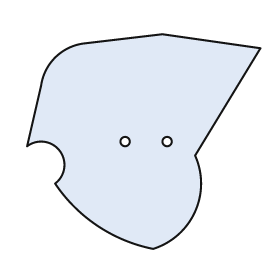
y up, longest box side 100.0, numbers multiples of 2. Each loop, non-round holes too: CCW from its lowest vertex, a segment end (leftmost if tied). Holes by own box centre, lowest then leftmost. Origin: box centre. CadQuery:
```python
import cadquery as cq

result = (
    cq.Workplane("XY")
    .moveTo(4.0, -46.0)
    .threePointArc((22.0, -30.0), (22.0, -6.0))
    .lineTo(50.0, 40.0)
    .lineTo(8.0, 46.0)
    .lineTo(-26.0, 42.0)
    .threePointArc((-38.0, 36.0), (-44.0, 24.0))
    .lineTo(-50.0, -2.0)
    .threePointArc((-36.0, -4.0), (-38.0, -18.0))
    .threePointArc((-20.0, -36.0), (4.0, -46.0))
    .close()
    .moveTo(-8.0, 0.0)
    .circle(2.0)
    .moveTo(10.0, 0.0)
    .circle(2.0)
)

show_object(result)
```